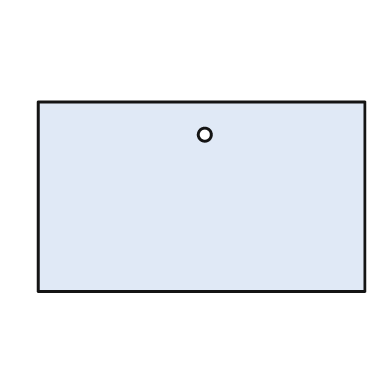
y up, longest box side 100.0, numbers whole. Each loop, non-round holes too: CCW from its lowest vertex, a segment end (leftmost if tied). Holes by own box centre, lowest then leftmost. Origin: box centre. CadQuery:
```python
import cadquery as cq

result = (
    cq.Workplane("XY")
    .moveTo(-50.0, -29.0)
    .lineTo(50.0, -29.0)
    .lineTo(50.0, 29.0)
    .lineTo(-50.0, 29.0)
    .close()
    .moveTo(1.0, 19.0)
    .circle(2.0)
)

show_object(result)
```